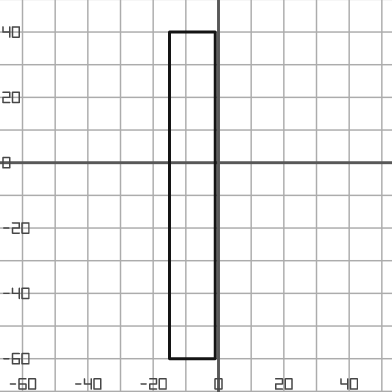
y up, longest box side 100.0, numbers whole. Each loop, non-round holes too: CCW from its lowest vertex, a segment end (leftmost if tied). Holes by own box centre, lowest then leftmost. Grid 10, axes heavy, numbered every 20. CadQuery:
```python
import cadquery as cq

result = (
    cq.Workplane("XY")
    .moveTo(-15.0, -60.0)
    .lineTo(-1.0, -60.0)
    .lineTo(-1.0, 40.0)
    .lineTo(-15.0, 40.0)
    .close()
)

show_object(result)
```